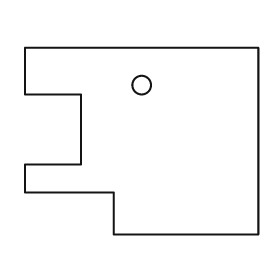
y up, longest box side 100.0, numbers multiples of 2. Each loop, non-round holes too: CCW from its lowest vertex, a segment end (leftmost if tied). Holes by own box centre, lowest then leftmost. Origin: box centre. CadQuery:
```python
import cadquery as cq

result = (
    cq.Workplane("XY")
    .moveTo(-12.0, -40.0)
    .lineTo(50.0, -40.0)
    .lineTo(50.0, 40.0)
    .lineTo(-50.0, 40.0)
    .lineTo(-50.0, 20.0)
    .lineTo(-26.0, 20.0)
    .lineTo(-26.0, -10.0)
    .lineTo(-50.0, -10.0)
    .lineTo(-50.0, -22.0)
    .lineTo(-12.0, -22.0)
    .close()
    .moveTo(0.0, 24.0)
    .circle(4.0)
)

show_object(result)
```